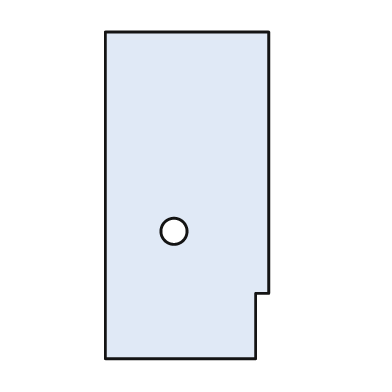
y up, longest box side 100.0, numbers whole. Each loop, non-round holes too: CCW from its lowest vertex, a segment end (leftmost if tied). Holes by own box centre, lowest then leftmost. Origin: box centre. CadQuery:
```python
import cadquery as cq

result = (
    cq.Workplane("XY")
    .moveTo(-25.0, -50.0)
    .lineTo(21.0, -50.0)
    .lineTo(21.0, -30.0)
    .lineTo(25.0, -30.0)
    .lineTo(25.0, 50.0)
    .lineTo(-25.0, 50.0)
    .close()
    .moveTo(-4.0, -11.0)
    .circle(4.0)
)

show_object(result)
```